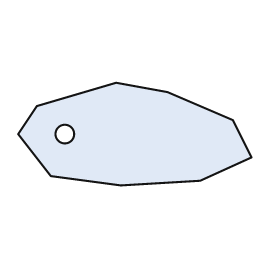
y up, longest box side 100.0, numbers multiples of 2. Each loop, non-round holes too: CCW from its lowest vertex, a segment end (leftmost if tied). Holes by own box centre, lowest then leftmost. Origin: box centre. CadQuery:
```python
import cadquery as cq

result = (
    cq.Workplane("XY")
    .moveTo(-6.0, -22.0)
    .lineTo(28.0, -20.0)
    .lineTo(50.0, -10.0)
    .lineTo(42.0, 6.0)
    .lineTo(14.0, 18.0)
    .lineTo(-8.0, 22.0)
    .lineTo(-42.0, 12.0)
    .lineTo(-50.0, 0.0)
    .lineTo(-36.0, -18.0)
    .close()
    .moveTo(-30.0, 0.0)
    .circle(4.0)
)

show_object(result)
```